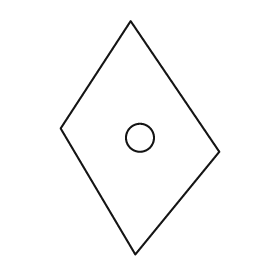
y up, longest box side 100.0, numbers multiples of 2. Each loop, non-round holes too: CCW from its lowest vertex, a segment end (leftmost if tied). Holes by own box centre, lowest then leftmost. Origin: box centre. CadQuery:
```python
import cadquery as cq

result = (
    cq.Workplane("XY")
    .moveTo(-2.0, -50.0)
    .lineTo(34.0, -6.0)
    .lineTo(-4.0, 50.0)
    .lineTo(-34.0, 4.0)
    .close()
    .moveTo(0.0, 0.0)
    .circle(6.0)
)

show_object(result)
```